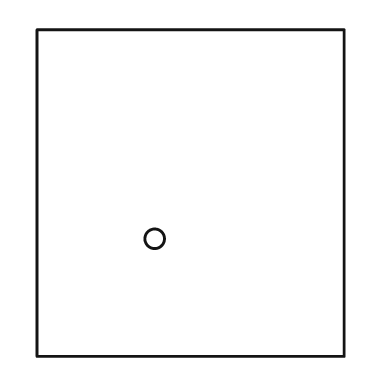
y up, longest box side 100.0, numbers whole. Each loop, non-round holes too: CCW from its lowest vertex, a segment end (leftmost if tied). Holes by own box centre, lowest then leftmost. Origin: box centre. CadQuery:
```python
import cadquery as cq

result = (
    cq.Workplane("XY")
    .moveTo(-47.0, -50.0)
    .lineTo(47.0, -50.0)
    .lineTo(47.0, 50.0)
    .lineTo(-47.0, 50.0)
    .close()
    .moveTo(-11.0, -14.0)
    .circle(3.0)
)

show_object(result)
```